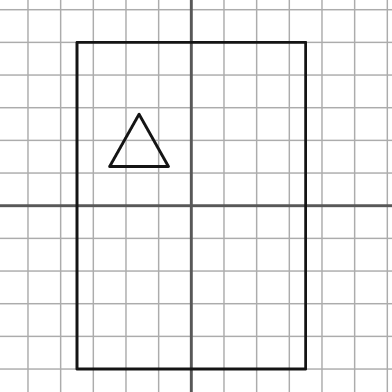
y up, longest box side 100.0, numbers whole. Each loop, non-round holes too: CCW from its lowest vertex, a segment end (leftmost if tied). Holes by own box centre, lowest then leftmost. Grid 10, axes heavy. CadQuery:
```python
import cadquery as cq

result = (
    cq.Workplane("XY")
    .moveTo(-35.0, -50.0)
    .lineTo(35.0, -50.0)
    .lineTo(35.0, 50.0)
    .lineTo(-35.0, 50.0)
    .close()
    .moveTo(-25.0, 12.0)
    .lineTo(-7.0, 12.0)
    .lineTo(-16.0, 28.0)
    .close()
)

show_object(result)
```